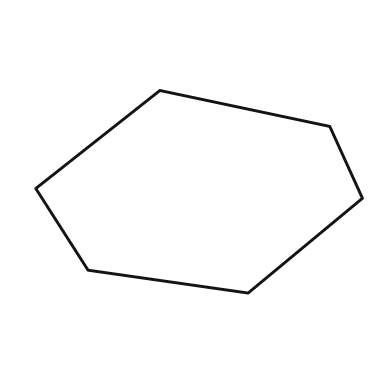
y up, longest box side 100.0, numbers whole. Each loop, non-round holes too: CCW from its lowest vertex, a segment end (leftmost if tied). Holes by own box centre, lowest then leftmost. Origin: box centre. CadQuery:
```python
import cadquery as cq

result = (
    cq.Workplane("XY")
    .moveTo(15.0, -31.0)
    .lineTo(50.0, -2.0)
    .lineTo(40.0, 20.0)
    .lineTo(-12.0, 31.0)
    .lineTo(-50.0, 1.0)
    .lineTo(-34.0, -24.0)
    .close()
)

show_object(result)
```